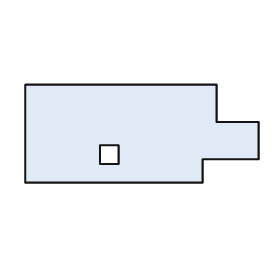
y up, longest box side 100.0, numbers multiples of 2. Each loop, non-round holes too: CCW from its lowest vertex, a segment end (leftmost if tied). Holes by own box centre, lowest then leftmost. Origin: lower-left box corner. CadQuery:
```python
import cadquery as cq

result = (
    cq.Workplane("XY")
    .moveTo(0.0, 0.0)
    .lineTo(76.0, 0.0)
    .lineTo(76.0, 10.0)
    .lineTo(100.0, 10.0)
    .lineTo(100.0, 26.0)
    .lineTo(82.0, 26.0)
    .lineTo(82.0, 42.0)
    .lineTo(0.0, 42.0)
    .close()
    .moveTo(32.0, 8.0)
    .lineTo(40.0, 8.0)
    .lineTo(40.0, 16.0)
    .lineTo(32.0, 16.0)
    .close()
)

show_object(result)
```